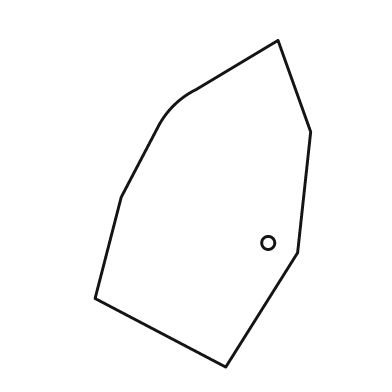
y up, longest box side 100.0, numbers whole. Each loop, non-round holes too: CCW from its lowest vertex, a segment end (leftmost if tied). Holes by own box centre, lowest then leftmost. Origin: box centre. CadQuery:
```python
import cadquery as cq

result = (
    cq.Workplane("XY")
    .moveTo(7.0, -50.0)
    .lineTo(29.0, -15.0)
    .lineTo(33.0, 22.0)
    .lineTo(23.0, 50.0)
    .lineTo(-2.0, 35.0)
    .threePointArc((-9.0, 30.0), (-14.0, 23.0))
    .lineTo(-25.0, 2.0)
    .lineTo(-33.0, -29.0)
    .close()
    .moveTo(20.0, -12.0)
    .circle(2.0)
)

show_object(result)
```